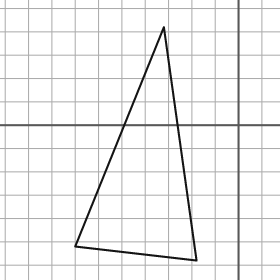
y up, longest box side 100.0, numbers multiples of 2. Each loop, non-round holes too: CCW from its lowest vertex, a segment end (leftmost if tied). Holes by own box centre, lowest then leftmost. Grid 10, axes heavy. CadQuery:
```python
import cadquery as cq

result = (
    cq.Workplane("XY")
    .moveTo(-18.0, -58.0)
    .lineTo(-32.0, 42.0)
    .lineTo(-70.0, -52.0)
    .close()
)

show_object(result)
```